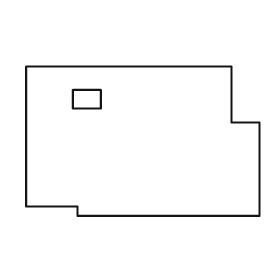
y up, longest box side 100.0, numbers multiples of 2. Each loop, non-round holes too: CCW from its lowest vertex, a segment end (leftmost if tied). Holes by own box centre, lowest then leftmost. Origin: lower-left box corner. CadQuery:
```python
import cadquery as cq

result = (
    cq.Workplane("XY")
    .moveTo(22.0, 0.0)
    .lineTo(100.0, 0.0)
    .lineTo(100.0, 40.0)
    .lineTo(88.0, 40.0)
    .lineTo(88.0, 64.0)
    .lineTo(0.0, 64.0)
    .lineTo(0.0, 4.0)
    .lineTo(22.0, 4.0)
    .close()
    .moveTo(20.0, 46.0)
    .lineTo(32.0, 46.0)
    .lineTo(32.0, 54.0)
    .lineTo(20.0, 54.0)
    .close()
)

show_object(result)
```